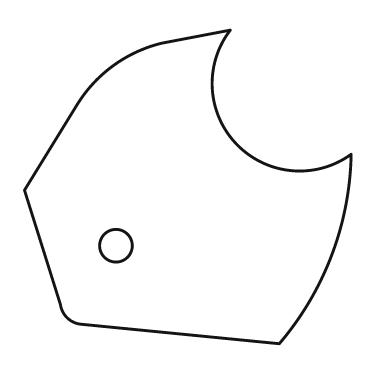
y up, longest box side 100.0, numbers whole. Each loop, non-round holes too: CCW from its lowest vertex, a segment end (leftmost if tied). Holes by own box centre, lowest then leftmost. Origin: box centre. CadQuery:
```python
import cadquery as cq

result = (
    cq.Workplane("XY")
    .moveTo(28.0, -48.0)
    .threePointArc((44.0, -21.0), (50.0, 10.0))
    .threePointArc((15.0, 13.0), (13.0, 48.0))
    .lineTo(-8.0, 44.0)
    .threePointArc((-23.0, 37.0), (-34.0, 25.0))
    .lineTo(-50.0, -1.0)
    .lineTo(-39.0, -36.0)
    .threePointArc((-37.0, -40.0), (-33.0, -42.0))
    .close()
    .moveTo(-22.0, -18.0)
    .circle(5.0)
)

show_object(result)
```